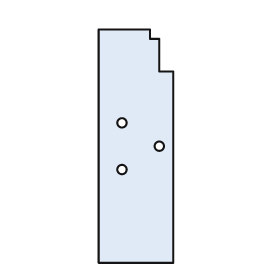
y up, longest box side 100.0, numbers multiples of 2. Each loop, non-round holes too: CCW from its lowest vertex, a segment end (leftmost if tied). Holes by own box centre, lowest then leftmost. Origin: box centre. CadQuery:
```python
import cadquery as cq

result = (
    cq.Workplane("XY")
    .moveTo(-16.0, -50.0)
    .lineTo(16.0, -50.0)
    .lineTo(16.0, 32.0)
    .lineTo(10.0, 32.0)
    .lineTo(10.0, 46.0)
    .lineTo(6.0, 46.0)
    .lineTo(6.0, 50.0)
    .lineTo(-16.0, 50.0)
    .close()
    .moveTo(-6.0, -10.0)
    .circle(2.0)
    .moveTo(10.0, 0.0)
    .circle(2.0)
    .moveTo(-6.0, 10.0)
    .circle(2.0)
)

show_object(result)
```